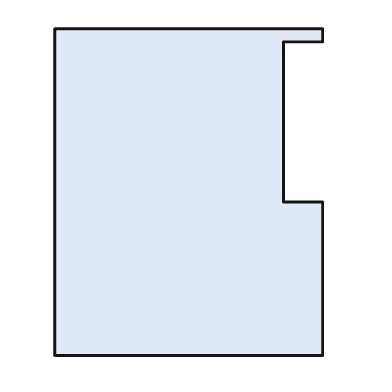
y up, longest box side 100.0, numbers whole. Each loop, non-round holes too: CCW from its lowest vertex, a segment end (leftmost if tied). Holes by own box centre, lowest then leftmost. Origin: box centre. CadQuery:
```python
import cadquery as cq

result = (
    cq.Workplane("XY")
    .moveTo(-41.0, -50.0)
    .lineTo(41.0, -50.0)
    .lineTo(41.0, -3.0)
    .lineTo(29.0, -3.0)
    .lineTo(29.0, 46.0)
    .lineTo(41.0, 46.0)
    .lineTo(41.0, 50.0)
    .lineTo(-41.0, 50.0)
    .close()
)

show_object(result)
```